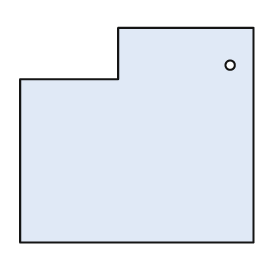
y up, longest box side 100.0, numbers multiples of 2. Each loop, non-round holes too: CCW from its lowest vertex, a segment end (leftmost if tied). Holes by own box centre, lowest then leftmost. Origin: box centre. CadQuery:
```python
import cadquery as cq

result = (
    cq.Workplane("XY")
    .moveTo(-50.0, -46.0)
    .lineTo(50.0, -46.0)
    .lineTo(50.0, 46.0)
    .lineTo(-8.0, 46.0)
    .lineTo(-8.0, 24.0)
    .lineTo(-50.0, 24.0)
    .close()
    .moveTo(40.0, 30.0)
    .circle(2.0)
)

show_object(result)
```